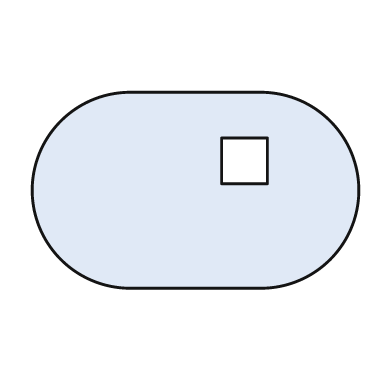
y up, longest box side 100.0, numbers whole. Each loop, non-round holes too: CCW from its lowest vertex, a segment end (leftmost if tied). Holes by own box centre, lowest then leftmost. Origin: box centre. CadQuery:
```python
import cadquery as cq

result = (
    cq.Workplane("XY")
    .moveTo(-20.0, -30.0)
    .lineTo(20.0, -30.0)
    .threePointArc((50.0, 0.0), (20.0, 30.0))
    .lineTo(-20.0, 30.0)
    .threePointArc((-50.0, 0.0), (-20.0, -30.0))
    .close()
    .moveTo(8.0, 2.0)
    .lineTo(22.0, 2.0)
    .lineTo(22.0, 16.0)
    .lineTo(8.0, 16.0)
    .close()
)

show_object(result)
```